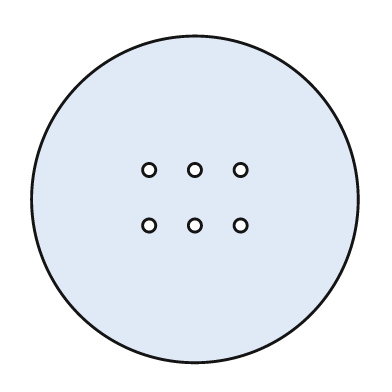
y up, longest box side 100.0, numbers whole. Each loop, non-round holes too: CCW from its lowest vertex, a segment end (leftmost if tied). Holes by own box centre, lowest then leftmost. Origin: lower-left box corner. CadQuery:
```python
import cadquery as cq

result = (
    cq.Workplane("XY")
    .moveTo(50.0, 50.0)
    .circle(50.0)
    .moveTo(36.0, 42.0)
    .circle(2.0)
    .moveTo(50.0, 42.0)
    .circle(2.0)
    .moveTo(64.0, 42.0)
    .circle(2.0)
    .moveTo(36.0, 59.0)
    .circle(2.0)
    .moveTo(50.0, 59.0)
    .circle(2.0)
    .moveTo(64.0, 59.0)
    .circle(2.0)
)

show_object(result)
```